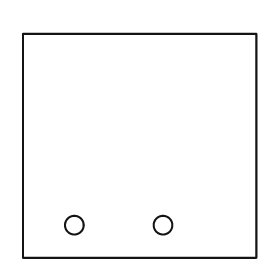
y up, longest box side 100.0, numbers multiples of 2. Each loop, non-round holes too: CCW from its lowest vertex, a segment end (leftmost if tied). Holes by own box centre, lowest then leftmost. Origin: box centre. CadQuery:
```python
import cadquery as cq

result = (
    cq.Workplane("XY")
    .moveTo(-50.0, -48.0)
    .lineTo(50.0, -48.0)
    .lineTo(50.0, 48.0)
    .lineTo(-50.0, 48.0)
    .close()
    .moveTo(-28.0, -34.0)
    .circle(4.0)
    .moveTo(10.0, -34.0)
    .circle(4.0)
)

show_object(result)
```